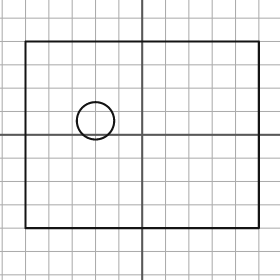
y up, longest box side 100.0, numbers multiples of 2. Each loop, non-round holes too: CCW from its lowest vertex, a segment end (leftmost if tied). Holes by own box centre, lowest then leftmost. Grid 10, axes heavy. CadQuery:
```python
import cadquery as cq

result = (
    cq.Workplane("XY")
    .moveTo(-50.0, -40.0)
    .lineTo(50.0, -40.0)
    .lineTo(50.0, 40.0)
    .lineTo(-50.0, 40.0)
    .close()
    .moveTo(-20.0, 6.0)
    .circle(8.0)
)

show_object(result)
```